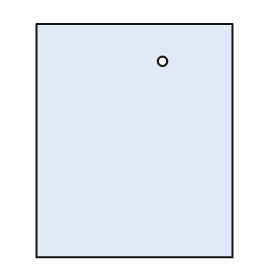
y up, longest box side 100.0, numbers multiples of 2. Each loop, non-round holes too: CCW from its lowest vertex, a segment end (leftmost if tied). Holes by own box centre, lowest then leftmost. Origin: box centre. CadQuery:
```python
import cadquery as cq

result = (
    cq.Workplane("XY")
    .moveTo(-42.0, -50.0)
    .lineTo(42.0, -50.0)
    .lineTo(42.0, 50.0)
    .lineTo(-42.0, 50.0)
    .close()
    .moveTo(12.0, 34.0)
    .circle(2.0)
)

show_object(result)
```